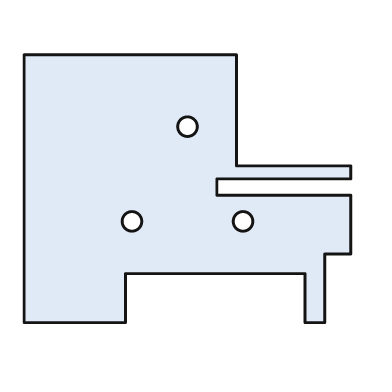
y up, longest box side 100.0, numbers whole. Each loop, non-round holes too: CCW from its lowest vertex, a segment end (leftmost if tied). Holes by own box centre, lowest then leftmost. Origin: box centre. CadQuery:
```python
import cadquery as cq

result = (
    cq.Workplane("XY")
    .moveTo(-50.0, -41.0)
    .lineTo(-19.0, -41.0)
    .lineTo(-19.0, -26.0)
    .lineTo(36.0, -26.0)
    .lineTo(36.0, -41.0)
    .lineTo(42.0, -41.0)
    .lineTo(42.0, -20.0)
    .lineTo(50.0, -20.0)
    .lineTo(50.0, -2.0)
    .lineTo(9.0, -2.0)
    .lineTo(9.0, 3.0)
    .lineTo(50.0, 3.0)
    .lineTo(50.0, 7.0)
    .lineTo(15.0, 7.0)
    .lineTo(15.0, 41.0)
    .lineTo(-50.0, 41.0)
    .close()
    .moveTo(-17.0, -10.0)
    .circle(3.0)
    .moveTo(17.0, -10.0)
    .circle(3.0)
    .moveTo(0.0, 19.0)
    .circle(3.0)
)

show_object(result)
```